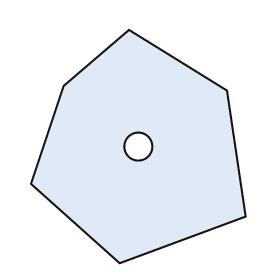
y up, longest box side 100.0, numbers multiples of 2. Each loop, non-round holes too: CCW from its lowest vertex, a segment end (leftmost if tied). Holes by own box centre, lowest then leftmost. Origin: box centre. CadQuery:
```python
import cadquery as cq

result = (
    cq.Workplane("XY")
    .moveTo(-8.0, -50.0)
    .lineTo(46.0, -30.0)
    .lineTo(38.0, 24.0)
    .lineTo(-4.0, 50.0)
    .lineTo(-32.0, 26.0)
    .lineTo(-46.0, -16.0)
    .close()
    .moveTo(0.0, 0.0)
    .circle(6.0)
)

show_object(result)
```